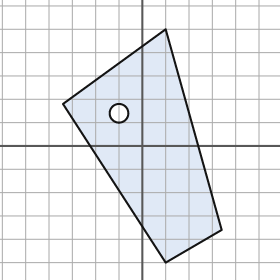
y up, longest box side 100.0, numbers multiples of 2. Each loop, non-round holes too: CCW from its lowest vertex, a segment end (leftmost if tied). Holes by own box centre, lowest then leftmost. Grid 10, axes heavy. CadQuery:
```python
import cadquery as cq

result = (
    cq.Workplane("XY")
    .moveTo(10.0, -50.0)
    .lineTo(34.0, -36.0)
    .lineTo(10.0, 50.0)
    .lineTo(-34.0, 18.0)
    .close()
    .moveTo(-10.0, 14.0)
    .circle(4.0)
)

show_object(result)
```